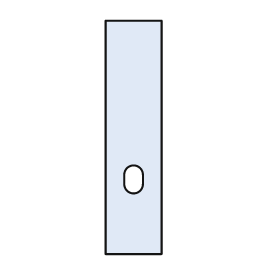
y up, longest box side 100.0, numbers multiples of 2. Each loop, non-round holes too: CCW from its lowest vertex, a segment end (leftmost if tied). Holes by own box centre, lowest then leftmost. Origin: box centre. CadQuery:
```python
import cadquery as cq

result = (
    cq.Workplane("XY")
    .moveTo(-12.0, -50.0)
    .lineTo(12.0, -50.0)
    .lineTo(12.0, 50.0)
    .lineTo(-12.0, 50.0)
    .close()
    .moveTo(-4.0, -20.0)
    .threePointArc((0.0, -24.0), (4.0, -20.0))
    .lineTo(4.0, -16.0)
    .threePointArc((0.0, -12.0), (-4.0, -16.0))
    .close()
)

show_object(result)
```